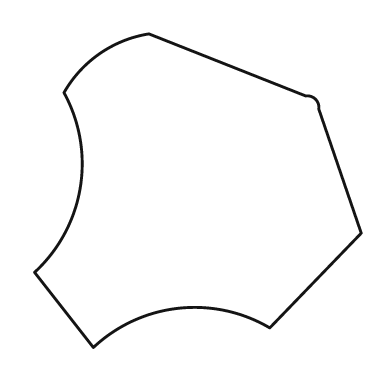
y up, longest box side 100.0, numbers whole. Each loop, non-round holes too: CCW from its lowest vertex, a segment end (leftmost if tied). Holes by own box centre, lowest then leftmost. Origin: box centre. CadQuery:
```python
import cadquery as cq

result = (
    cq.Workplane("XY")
    .moveTo(-32.0, -48.0)
    .threePointArc((-6.0, -36.0), (22.0, -42.0))
    .lineTo(50.0, -13.0)
    .lineTo(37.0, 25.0)
    .threePointArc((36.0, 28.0), (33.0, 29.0))
    .lineTo(-15.0, 48.0)
    .threePointArc((-30.0, 42.0), (-41.0, 30.0))
    .threePointArc((-36.0, 1.0), (-50.0, -25.0))
    .close()
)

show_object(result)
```